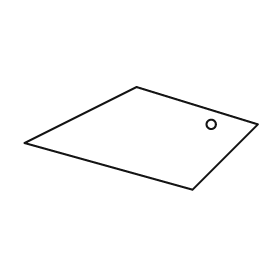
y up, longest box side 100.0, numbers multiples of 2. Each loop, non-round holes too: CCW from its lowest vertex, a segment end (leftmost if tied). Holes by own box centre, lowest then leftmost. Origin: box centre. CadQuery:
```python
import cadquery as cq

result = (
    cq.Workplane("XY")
    .moveTo(22.0, -22.0)
    .lineTo(50.0, 6.0)
    .lineTo(-2.0, 22.0)
    .lineTo(-50.0, -2.0)
    .close()
    .moveTo(30.0, 6.0)
    .circle(2.0)
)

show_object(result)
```